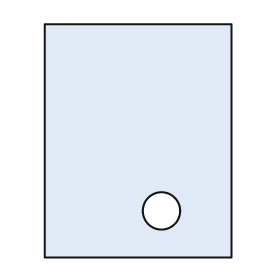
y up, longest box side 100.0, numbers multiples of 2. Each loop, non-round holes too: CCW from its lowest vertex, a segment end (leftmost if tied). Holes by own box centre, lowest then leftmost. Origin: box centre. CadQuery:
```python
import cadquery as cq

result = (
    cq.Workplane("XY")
    .moveTo(-40.0, -50.0)
    .lineTo(40.0, -50.0)
    .lineTo(40.0, 50.0)
    .lineTo(-40.0, 50.0)
    .close()
    .moveTo(10.0, -30.0)
    .circle(8.0)
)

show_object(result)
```